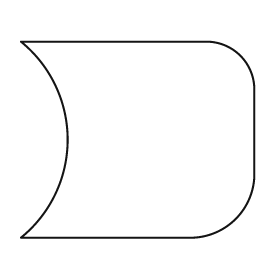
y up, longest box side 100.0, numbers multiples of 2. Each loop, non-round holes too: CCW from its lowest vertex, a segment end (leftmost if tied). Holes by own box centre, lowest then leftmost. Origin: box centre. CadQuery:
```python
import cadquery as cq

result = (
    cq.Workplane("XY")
    .moveTo(-50.0, -42.0)
    .lineTo(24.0, -42.0)
    .threePointArc((42.0, -34.0), (50.0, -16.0))
    .lineTo(50.0, 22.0)
    .threePointArc((44.0, 36.0), (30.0, 42.0))
    .lineTo(-50.0, 42.0)
    .threePointArc((-30.0, 0.0), (-50.0, -42.0))
    .close()
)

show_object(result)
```